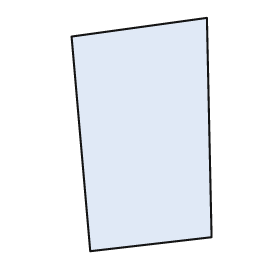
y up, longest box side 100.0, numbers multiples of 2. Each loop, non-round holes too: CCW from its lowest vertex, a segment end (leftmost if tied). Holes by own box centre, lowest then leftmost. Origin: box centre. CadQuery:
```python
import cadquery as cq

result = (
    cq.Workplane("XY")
    .moveTo(-22.0, -50.0)
    .lineTo(30.0, -44.0)
    .lineTo(28.0, 50.0)
    .lineTo(-30.0, 42.0)
    .close()
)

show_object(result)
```